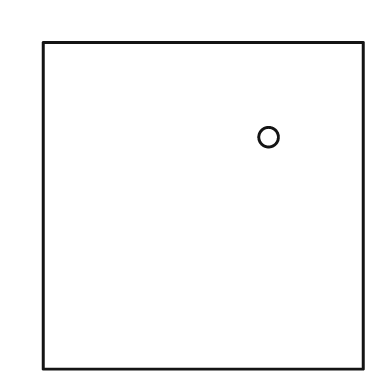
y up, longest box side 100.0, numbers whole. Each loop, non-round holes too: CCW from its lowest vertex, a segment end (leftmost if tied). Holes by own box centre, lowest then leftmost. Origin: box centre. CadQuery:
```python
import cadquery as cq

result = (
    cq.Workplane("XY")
    .moveTo(-49.0, -50.0)
    .lineTo(49.0, -50.0)
    .lineTo(49.0, 50.0)
    .lineTo(-49.0, 50.0)
    .close()
    .moveTo(20.0, 21.0)
    .circle(3.0)
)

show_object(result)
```